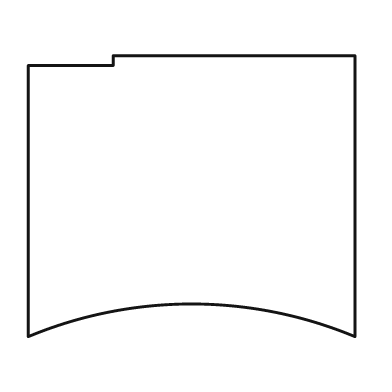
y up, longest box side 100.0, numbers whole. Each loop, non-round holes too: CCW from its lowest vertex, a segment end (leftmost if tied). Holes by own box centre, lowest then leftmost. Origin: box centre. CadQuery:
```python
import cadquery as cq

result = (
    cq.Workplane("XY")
    .moveTo(-50.0, -43.0)
    .threePointArc((0.0, -33.0), (50.0, -43.0))
    .lineTo(50.0, 43.0)
    .lineTo(-24.0, 43.0)
    .lineTo(-24.0, 40.0)
    .lineTo(-50.0, 40.0)
    .close()
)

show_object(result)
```